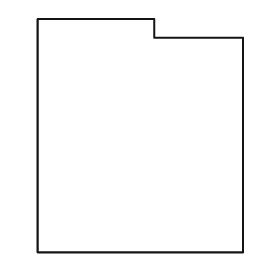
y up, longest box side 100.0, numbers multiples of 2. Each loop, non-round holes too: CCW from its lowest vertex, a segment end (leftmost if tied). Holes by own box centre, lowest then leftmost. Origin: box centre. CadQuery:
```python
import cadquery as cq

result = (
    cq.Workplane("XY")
    .moveTo(-44.0, -50.0)
    .lineTo(44.0, -50.0)
    .lineTo(44.0, 42.0)
    .lineTo(6.0, 42.0)
    .lineTo(6.0, 50.0)
    .lineTo(-44.0, 50.0)
    .close()
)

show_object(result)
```